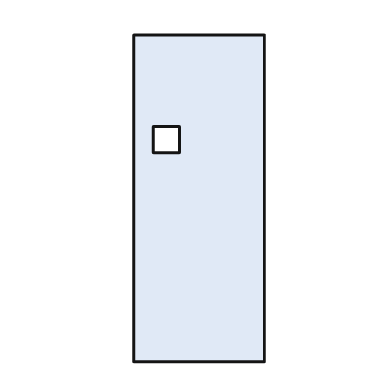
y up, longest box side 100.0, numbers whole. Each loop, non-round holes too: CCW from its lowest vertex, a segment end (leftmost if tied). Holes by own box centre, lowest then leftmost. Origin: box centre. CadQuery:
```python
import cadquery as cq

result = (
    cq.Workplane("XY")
    .moveTo(-20.0, -50.0)
    .lineTo(20.0, -50.0)
    .lineTo(20.0, 50.0)
    .lineTo(-20.0, 50.0)
    .close()
    .moveTo(-14.0, 14.0)
    .lineTo(-6.0, 14.0)
    .lineTo(-6.0, 22.0)
    .lineTo(-14.0, 22.0)
    .close()
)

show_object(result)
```